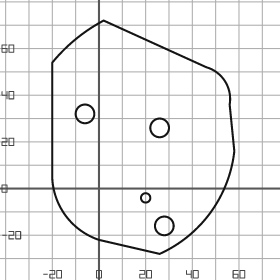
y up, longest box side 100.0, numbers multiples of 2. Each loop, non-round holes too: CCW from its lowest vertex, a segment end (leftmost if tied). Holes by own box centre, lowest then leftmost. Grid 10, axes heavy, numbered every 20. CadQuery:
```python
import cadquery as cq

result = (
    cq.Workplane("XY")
    .moveTo(26.0, -28.0)
    .threePointArc((48.0, -10.0), (58.0, 16.0))
    .lineTo(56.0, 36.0)
    .threePointArc((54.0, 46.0), (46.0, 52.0))
    .lineTo(2.0, 72.0)
    .threePointArc((-10.0, 64.0), (-20.0, 54.0))
    .lineTo(-20.0, 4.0)
    .threePointArc((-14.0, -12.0), (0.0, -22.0))
    .close()
    .moveTo(28.0, -16.0)
    .circle(4.0)
    .moveTo(20.0, -4.0)
    .circle(2.0)
    .moveTo(26.0, 26.0)
    .circle(4.0)
    .moveTo(-6.0, 32.0)
    .circle(4.0)
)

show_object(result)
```